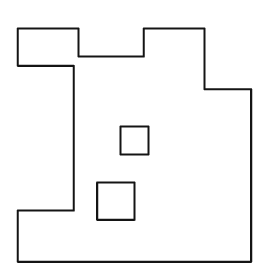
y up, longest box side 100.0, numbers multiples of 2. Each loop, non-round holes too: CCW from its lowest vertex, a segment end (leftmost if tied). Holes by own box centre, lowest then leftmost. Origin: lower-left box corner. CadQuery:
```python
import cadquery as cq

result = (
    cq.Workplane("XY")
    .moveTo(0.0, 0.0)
    .lineTo(100.0, 0.0)
    .lineTo(100.0, 74.0)
    .lineTo(80.0, 74.0)
    .lineTo(80.0, 100.0)
    .lineTo(54.0, 100.0)
    .lineTo(54.0, 88.0)
    .lineTo(26.0, 88.0)
    .lineTo(26.0, 100.0)
    .lineTo(0.0, 100.0)
    .lineTo(0.0, 84.0)
    .lineTo(24.0, 84.0)
    .lineTo(24.0, 22.0)
    .lineTo(0.0, 22.0)
    .close()
    .moveTo(34.0, 18.0)
    .lineTo(50.0, 18.0)
    .lineTo(50.0, 34.0)
    .lineTo(34.0, 34.0)
    .close()
    .moveTo(44.0, 46.0)
    .lineTo(56.0, 46.0)
    .lineTo(56.0, 58.0)
    .lineTo(44.0, 58.0)
    .close()
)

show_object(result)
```